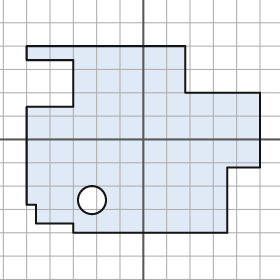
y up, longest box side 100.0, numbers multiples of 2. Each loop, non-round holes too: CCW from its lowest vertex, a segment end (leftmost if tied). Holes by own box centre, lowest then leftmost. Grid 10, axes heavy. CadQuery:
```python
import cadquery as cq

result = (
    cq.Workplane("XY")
    .moveTo(-30.0, -40.0)
    .lineTo(36.0, -40.0)
    .lineTo(36.0, -12.0)
    .lineTo(50.0, -12.0)
    .lineTo(50.0, 20.0)
    .lineTo(18.0, 20.0)
    .lineTo(18.0, 40.0)
    .lineTo(-50.0, 40.0)
    .lineTo(-50.0, 34.0)
    .lineTo(-30.0, 34.0)
    .lineTo(-30.0, 14.0)
    .lineTo(-50.0, 14.0)
    .lineTo(-50.0, -28.0)
    .lineTo(-46.0, -28.0)
    .lineTo(-46.0, -36.0)
    .lineTo(-30.0, -36.0)
    .close()
    .moveTo(-22.0, -26.0)
    .circle(6.0)
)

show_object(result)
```